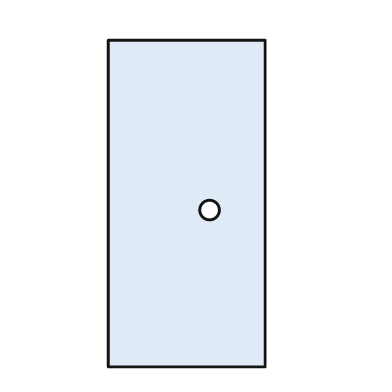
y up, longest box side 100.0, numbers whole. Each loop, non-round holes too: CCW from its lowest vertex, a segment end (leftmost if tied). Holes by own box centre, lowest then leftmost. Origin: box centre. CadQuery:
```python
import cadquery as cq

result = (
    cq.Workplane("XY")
    .moveTo(-24.0, -50.0)
    .lineTo(24.0, -50.0)
    .lineTo(24.0, 50.0)
    .lineTo(-24.0, 50.0)
    .close()
    .moveTo(7.0, -2.0)
    .circle(3.0)
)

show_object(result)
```